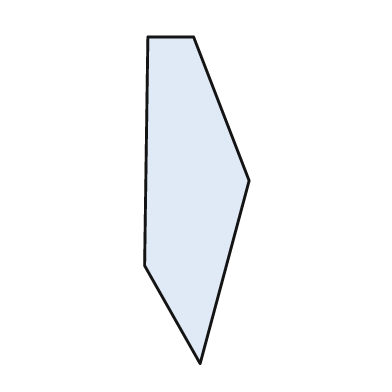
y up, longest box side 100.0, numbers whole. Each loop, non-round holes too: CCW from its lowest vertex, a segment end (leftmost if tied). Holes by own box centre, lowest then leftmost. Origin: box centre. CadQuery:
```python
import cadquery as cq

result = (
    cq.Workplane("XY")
    .moveTo(1.0, -50.0)
    .lineTo(16.0, 6.0)
    .lineTo(-1.0, 50.0)
    .lineTo(-15.0, 50.0)
    .lineTo(-16.0, -20.0)
    .close()
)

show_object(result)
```